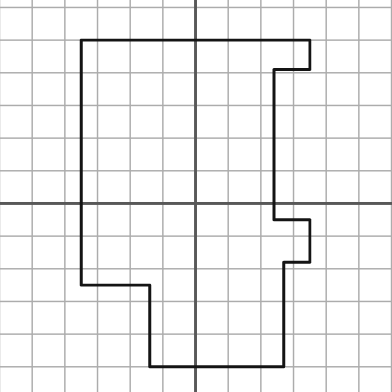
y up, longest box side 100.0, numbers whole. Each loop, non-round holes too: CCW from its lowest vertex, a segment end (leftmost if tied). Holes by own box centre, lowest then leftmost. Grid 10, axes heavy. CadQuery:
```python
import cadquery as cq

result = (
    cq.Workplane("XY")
    .moveTo(-14.0, -50.0)
    .lineTo(27.0, -50.0)
    .lineTo(27.0, -18.0)
    .lineTo(35.0, -18.0)
    .lineTo(35.0, -5.0)
    .lineTo(24.0, -5.0)
    .lineTo(24.0, 41.0)
    .lineTo(35.0, 41.0)
    .lineTo(35.0, 50.0)
    .lineTo(-35.0, 50.0)
    .lineTo(-35.0, -25.0)
    .lineTo(-14.0, -25.0)
    .close()
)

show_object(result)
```